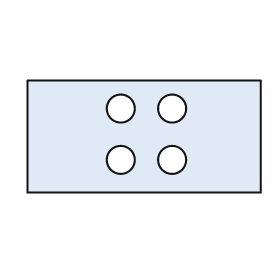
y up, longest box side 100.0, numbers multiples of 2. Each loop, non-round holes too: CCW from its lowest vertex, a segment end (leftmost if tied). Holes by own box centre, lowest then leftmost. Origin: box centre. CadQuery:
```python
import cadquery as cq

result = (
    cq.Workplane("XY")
    .moveTo(-50.0, -24.0)
    .lineTo(50.0, -24.0)
    .lineTo(50.0, 24.0)
    .lineTo(-50.0, 24.0)
    .close()
    .moveTo(-10.0, -10.0)
    .circle(6.0)
    .moveTo(12.0, -10.0)
    .circle(6.0)
    .moveTo(-10.0, 12.0)
    .circle(6.0)
    .moveTo(12.0, 12.0)
    .circle(6.0)
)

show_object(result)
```